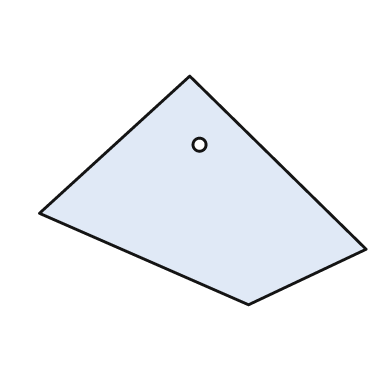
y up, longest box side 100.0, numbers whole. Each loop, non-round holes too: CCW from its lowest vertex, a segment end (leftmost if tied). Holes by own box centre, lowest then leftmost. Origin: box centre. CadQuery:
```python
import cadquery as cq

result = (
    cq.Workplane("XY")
    .moveTo(14.0, -35.0)
    .lineTo(50.0, -18.0)
    .lineTo(-4.0, 35.0)
    .lineTo(-50.0, -7.0)
    .close()
    .moveTo(-1.0, 14.0)
    .circle(2.0)
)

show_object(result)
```